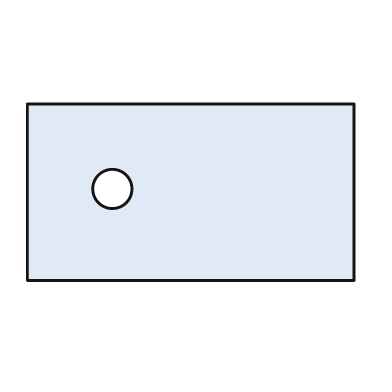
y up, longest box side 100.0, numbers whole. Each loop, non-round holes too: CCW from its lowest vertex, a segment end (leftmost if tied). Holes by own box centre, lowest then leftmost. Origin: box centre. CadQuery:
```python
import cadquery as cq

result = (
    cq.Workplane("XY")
    .moveTo(-50.0, -27.0)
    .lineTo(50.0, -27.0)
    .lineTo(50.0, 27.0)
    .lineTo(-50.0, 27.0)
    .close()
    .moveTo(-24.0, 1.0)
    .circle(6.0)
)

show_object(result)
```